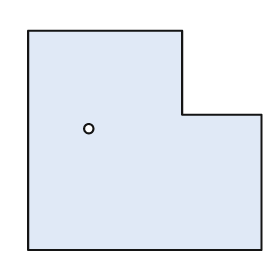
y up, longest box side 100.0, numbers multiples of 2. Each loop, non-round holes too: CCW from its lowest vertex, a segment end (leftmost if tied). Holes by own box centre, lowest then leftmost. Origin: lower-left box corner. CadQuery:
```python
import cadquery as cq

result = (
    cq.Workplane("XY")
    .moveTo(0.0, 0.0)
    .lineTo(100.0, 0.0)
    .lineTo(100.0, 58.0)
    .lineTo(66.0, 58.0)
    .lineTo(66.0, 94.0)
    .lineTo(0.0, 94.0)
    .close()
    .moveTo(26.0, 52.0)
    .circle(2.0)
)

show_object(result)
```